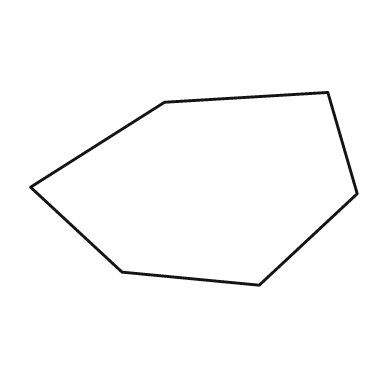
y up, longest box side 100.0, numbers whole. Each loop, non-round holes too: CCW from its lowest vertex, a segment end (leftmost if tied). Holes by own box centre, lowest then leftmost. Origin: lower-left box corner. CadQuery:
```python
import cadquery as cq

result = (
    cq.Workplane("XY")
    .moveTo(70.0, 0.0)
    .lineTo(100.0, 28.0)
    .lineTo(91.0, 59.0)
    .lineTo(41.0, 56.0)
    .lineTo(0.0, 30.0)
    .lineTo(28.0, 4.0)
    .close()
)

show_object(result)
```